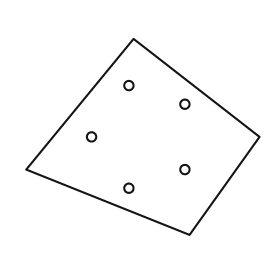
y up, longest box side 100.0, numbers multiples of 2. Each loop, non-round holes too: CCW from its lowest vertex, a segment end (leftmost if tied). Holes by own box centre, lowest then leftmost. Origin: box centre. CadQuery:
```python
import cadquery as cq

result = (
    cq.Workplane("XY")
    .moveTo(20.0, -42.0)
    .lineTo(50.0, 0.0)
    .lineTo(-4.0, 42.0)
    .lineTo(-50.0, -14.0)
    .close()
    .moveTo(-6.0, -22.0)
    .circle(2.0)
    .moveTo(18.0, -14.0)
    .circle(2.0)
    .moveTo(-22.0, 0.0)
    .circle(2.0)
    .moveTo(18.0, 14.0)
    .circle(2.0)
    .moveTo(-6.0, 22.0)
    .circle(2.0)
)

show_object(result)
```